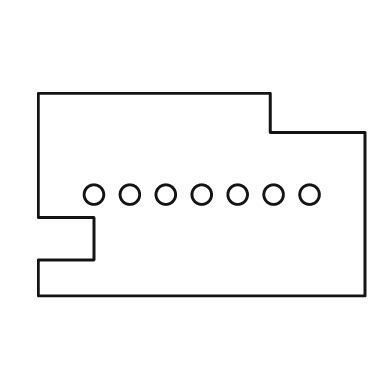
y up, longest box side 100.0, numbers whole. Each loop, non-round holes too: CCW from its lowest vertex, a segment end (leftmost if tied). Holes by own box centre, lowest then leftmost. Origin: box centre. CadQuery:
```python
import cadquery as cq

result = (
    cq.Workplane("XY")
    .moveTo(-50.0, -31.0)
    .lineTo(50.0, -31.0)
    .lineTo(50.0, 19.0)
    .lineTo(21.0, 19.0)
    .lineTo(21.0, 31.0)
    .lineTo(-50.0, 31.0)
    .lineTo(-50.0, -7.0)
    .lineTo(-33.0, -7.0)
    .lineTo(-33.0, -20.0)
    .lineTo(-50.0, -20.0)
    .close()
    .moveTo(-33.0, 0.0)
    .circle(3.0)
    .moveTo(-22.0, 0.0)
    .circle(3.0)
    .moveTo(-11.0, 0.0)
    .circle(3.0)
    .moveTo(0.0, 0.0)
    .circle(3.0)
    .moveTo(11.0, 0.0)
    .circle(3.0)
    .moveTo(22.0, 0.0)
    .circle(3.0)
    .moveTo(33.0, 0.0)
    .circle(3.0)
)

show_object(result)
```